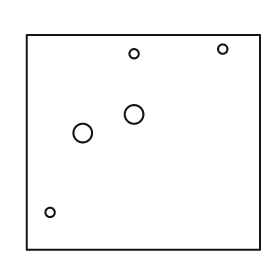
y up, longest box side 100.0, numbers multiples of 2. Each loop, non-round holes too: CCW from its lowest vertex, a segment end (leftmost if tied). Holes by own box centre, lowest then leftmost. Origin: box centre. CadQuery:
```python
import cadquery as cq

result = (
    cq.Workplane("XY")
    .moveTo(-50.0, -46.0)
    .lineTo(50.0, -46.0)
    .lineTo(50.0, 46.0)
    .lineTo(-50.0, 46.0)
    .close()
    .moveTo(-40.0, -30.0)
    .circle(2.0)
    .moveTo(-26.0, 4.0)
    .circle(4.0)
    .moveTo(-4.0, 12.0)
    .circle(4.0)
    .moveTo(-4.0, 38.0)
    .circle(2.0)
    .moveTo(34.0, 40.0)
    .circle(2.0)
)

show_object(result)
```